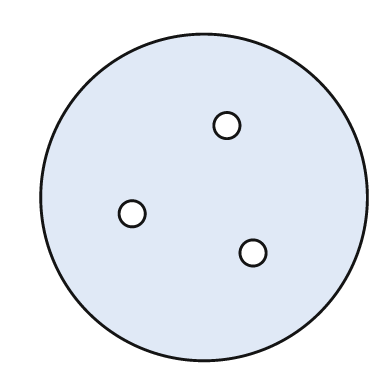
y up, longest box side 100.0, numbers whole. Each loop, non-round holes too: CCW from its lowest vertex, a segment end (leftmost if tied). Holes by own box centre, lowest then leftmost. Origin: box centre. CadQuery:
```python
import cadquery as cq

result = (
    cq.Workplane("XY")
    .moveTo(0.0, 0.0)
    .circle(50.0)
    .moveTo(15.0, -17.0)
    .circle(4.0)
    .moveTo(-22.0, -5.0)
    .circle(4.0)
    .moveTo(7.0, 22.0)
    .circle(4.0)
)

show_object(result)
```